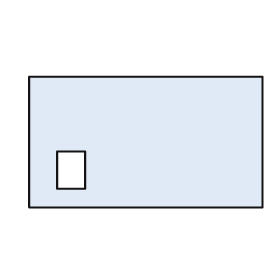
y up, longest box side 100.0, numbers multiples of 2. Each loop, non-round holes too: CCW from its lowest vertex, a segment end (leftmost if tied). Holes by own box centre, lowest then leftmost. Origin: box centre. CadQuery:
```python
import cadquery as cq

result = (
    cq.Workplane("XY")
    .moveTo(-50.0, -28.0)
    .lineTo(50.0, -28.0)
    .lineTo(50.0, 28.0)
    .lineTo(-50.0, 28.0)
    .close()
    .moveTo(-38.0, -20.0)
    .lineTo(-26.0, -20.0)
    .lineTo(-26.0, -4.0)
    .lineTo(-38.0, -4.0)
    .close()
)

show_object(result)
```